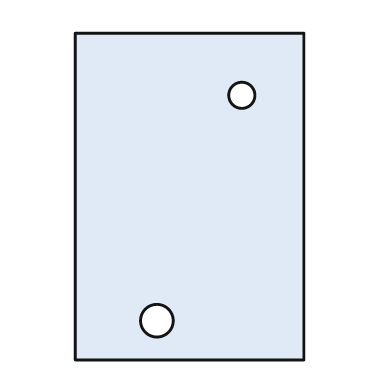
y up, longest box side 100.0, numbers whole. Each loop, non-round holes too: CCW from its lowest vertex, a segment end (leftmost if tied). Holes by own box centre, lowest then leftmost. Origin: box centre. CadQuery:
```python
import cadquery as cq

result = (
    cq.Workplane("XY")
    .moveTo(-35.0, -50.0)
    .lineTo(35.0, -50.0)
    .lineTo(35.0, 50.0)
    .lineTo(-35.0, 50.0)
    .close()
    .moveTo(-10.0, -38.0)
    .circle(5.0)
    .moveTo(16.0, 31.0)
    .circle(4.0)
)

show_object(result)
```